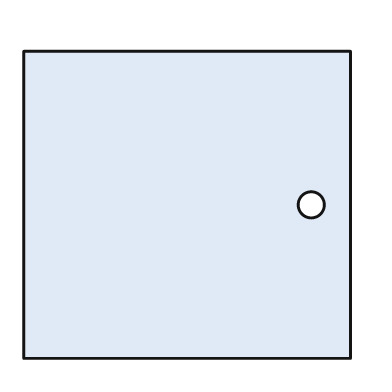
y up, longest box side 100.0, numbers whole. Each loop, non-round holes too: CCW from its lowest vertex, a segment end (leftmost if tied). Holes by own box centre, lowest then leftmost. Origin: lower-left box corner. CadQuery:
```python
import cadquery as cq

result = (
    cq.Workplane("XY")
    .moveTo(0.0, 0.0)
    .lineTo(100.0, 0.0)
    .lineTo(100.0, 94.0)
    .lineTo(0.0, 94.0)
    .close()
    .moveTo(88.0, 47.0)
    .circle(4.0)
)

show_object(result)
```